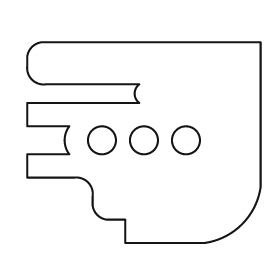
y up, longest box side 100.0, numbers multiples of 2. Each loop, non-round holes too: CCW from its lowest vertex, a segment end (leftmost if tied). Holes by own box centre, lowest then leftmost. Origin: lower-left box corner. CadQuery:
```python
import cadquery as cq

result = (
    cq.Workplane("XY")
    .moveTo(42.0, 0.0)
    .lineTo(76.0, 0.0)
    .threePointArc((92.0, 8.0), (100.0, 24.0))
    .lineTo(100.0, 86.0)
    .lineTo(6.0, 86.0)
    .threePointArc((2.0, 84.0), (0.0, 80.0))
    .lineTo(0.0, 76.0)
    .threePointArc((2.0, 70.0), (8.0, 68.0))
    .lineTo(48.0, 68.0)
    .threePointArc((46.0, 64.0), (48.0, 60.0))
    .lineTo(0.0, 60.0)
    .lineTo(0.0, 50.0)
    .lineTo(18.0, 50.0)
    .threePointArc((16.0, 44.0), (18.0, 38.0))
    .lineTo(0.0, 38.0)
    .lineTo(0.0, 28.0)
    .lineTo(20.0, 28.0)
    .threePointArc((26.0, 26.0), (28.0, 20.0))
    .lineTo(28.0, 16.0)
    .threePointArc((30.0, 12.0), (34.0, 10.0))
    .lineTo(42.0, 10.0)
    .close()
    .moveTo(32.0, 44.0)
    .circle(6.0)
    .moveTo(50.0, 44.0)
    .circle(6.0)
    .moveTo(68.0, 44.0)
    .circle(6.0)
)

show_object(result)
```